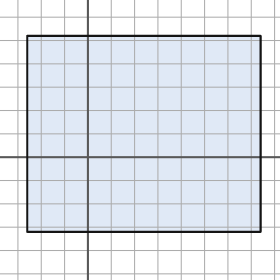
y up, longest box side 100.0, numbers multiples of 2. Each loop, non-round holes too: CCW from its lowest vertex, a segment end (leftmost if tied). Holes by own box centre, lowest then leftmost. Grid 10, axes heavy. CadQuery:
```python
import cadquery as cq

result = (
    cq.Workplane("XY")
    .moveTo(-26.0, -32.0)
    .lineTo(74.0, -32.0)
    .lineTo(74.0, 52.0)
    .lineTo(-26.0, 52.0)
    .close()
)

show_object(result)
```